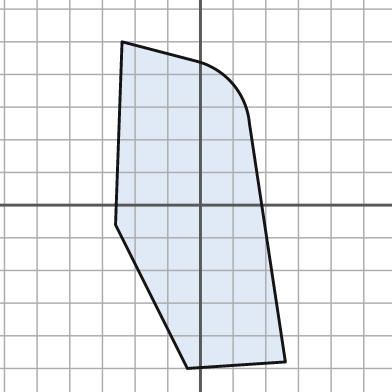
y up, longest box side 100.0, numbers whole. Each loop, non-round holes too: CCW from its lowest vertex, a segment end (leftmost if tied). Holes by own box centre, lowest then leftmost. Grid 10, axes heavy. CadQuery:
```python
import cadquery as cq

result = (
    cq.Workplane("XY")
    .moveTo(-4.0, -50.0)
    .lineTo(26.0, -48.0)
    .lineTo(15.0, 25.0)
    .threePointArc((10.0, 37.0), (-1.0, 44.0))
    .lineTo(-24.0, 50.0)
    .lineTo(-26.0, -6.0)
    .close()
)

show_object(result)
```